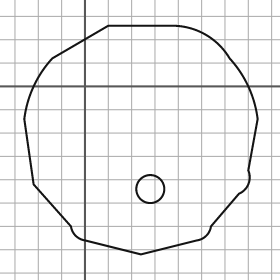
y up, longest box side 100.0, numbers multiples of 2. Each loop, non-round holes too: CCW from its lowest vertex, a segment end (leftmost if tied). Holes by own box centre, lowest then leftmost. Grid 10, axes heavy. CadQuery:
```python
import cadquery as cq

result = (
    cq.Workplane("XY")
    .moveTo(24.0, -72.0)
    .lineTo(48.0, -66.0)
    .threePointArc((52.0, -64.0), (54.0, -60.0))
    .lineTo(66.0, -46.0)
    .threePointArc((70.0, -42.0), (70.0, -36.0))
    .lineTo(74.0, -14.0)
    .threePointArc((70.0, 0.0), (62.0, 12.0))
    .threePointArc((52.0, 22.0), (38.0, 26.0))
    .lineTo(10.0, 26.0)
    .lineTo(-14.0, 12.0)
    .threePointArc((-22.0, 0.0), (-26.0, -14.0))
    .lineTo(-22.0, -42.0)
    .lineTo(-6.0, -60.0)
    .threePointArc((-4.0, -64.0), (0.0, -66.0))
    .close()
    .moveTo(28.0, -44.0)
    .circle(6.0)
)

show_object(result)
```